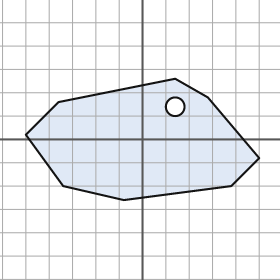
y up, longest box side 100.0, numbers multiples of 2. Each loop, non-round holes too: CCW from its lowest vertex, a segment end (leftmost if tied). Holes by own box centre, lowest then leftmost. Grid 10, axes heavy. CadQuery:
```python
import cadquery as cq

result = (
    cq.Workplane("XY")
    .moveTo(-8.0, -26.0)
    .lineTo(38.0, -20.0)
    .lineTo(50.0, -8.0)
    .lineTo(28.0, 18.0)
    .lineTo(14.0, 26.0)
    .lineTo(-36.0, 16.0)
    .lineTo(-50.0, 2.0)
    .lineTo(-34.0, -20.0)
    .close()
    .moveTo(14.0, 14.0)
    .circle(4.0)
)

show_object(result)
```